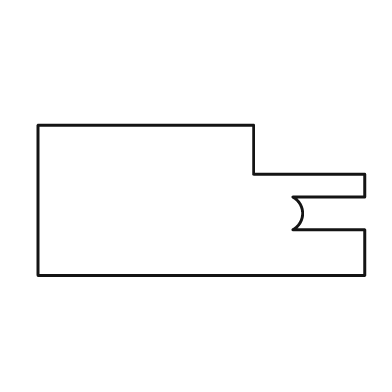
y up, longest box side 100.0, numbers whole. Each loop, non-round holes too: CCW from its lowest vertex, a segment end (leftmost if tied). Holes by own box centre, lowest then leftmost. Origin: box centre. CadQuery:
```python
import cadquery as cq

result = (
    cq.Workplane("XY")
    .moveTo(-50.0, -23.0)
    .lineTo(50.0, -23.0)
    .lineTo(50.0, -9.0)
    .lineTo(28.0, -9.0)
    .threePointArc((31.0, -4.0), (28.0, 1.0))
    .lineTo(50.0, 1.0)
    .lineTo(50.0, 8.0)
    .lineTo(16.0, 8.0)
    .lineTo(16.0, 23.0)
    .lineTo(-50.0, 23.0)
    .close()
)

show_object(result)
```